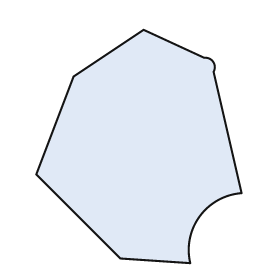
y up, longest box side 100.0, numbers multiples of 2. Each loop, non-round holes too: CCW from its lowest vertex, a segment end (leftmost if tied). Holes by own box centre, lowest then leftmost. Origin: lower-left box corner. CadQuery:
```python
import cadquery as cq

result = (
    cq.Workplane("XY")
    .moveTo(66.0, 0.0)
    .threePointArc((70.0, 20.0), (88.0, 30.0))
    .lineTo(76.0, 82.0)
    .threePointArc((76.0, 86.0), (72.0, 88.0))
    .lineTo(46.0, 100.0)
    .lineTo(16.0, 80.0)
    .lineTo(0.0, 38.0)
    .lineTo(36.0, 2.0)
    .close()
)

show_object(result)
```